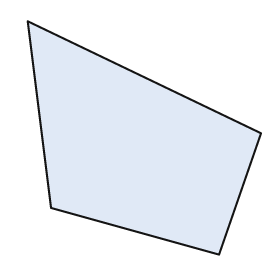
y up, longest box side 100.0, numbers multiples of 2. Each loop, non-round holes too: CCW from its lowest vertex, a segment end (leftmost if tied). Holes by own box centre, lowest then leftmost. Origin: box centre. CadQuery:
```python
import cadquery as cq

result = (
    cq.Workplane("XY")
    .moveTo(32.0, -50.0)
    .lineTo(50.0, 2.0)
    .lineTo(-50.0, 50.0)
    .lineTo(-40.0, -30.0)
    .close()
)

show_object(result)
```